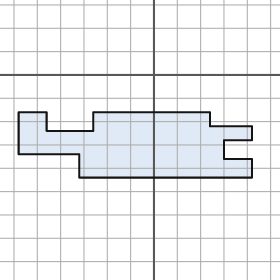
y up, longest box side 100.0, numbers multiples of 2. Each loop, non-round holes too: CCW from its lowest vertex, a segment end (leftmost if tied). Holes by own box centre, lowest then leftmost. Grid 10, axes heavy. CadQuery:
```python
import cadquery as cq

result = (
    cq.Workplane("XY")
    .moveTo(-32.0, -44.0)
    .lineTo(42.0, -44.0)
    .lineTo(42.0, -36.0)
    .lineTo(30.0, -36.0)
    .lineTo(30.0, -28.0)
    .lineTo(42.0, -28.0)
    .lineTo(42.0, -22.0)
    .lineTo(24.0, -22.0)
    .lineTo(24.0, -16.0)
    .lineTo(-26.0, -16.0)
    .lineTo(-26.0, -24.0)
    .lineTo(-46.0, -24.0)
    .lineTo(-46.0, -16.0)
    .lineTo(-58.0, -16.0)
    .lineTo(-58.0, -34.0)
    .lineTo(-32.0, -34.0)
    .close()
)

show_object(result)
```